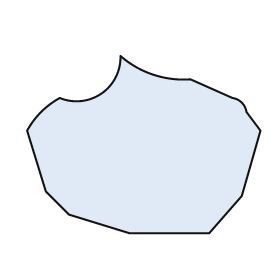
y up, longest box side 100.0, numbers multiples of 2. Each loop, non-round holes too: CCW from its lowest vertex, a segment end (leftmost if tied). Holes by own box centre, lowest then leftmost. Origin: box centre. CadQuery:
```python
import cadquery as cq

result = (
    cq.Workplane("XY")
    .moveTo(-6.0, -38.0)
    .lineTo(28.0, -38.0)
    .lineTo(42.0, -22.0)
    .lineTo(50.0, 6.0)
    .lineTo(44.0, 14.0)
    .threePointArc((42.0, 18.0), (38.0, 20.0))
    .lineTo(20.0, 28.0)
    .threePointArc((4.0, 30.0), (-10.0, 38.0))
    .threePointArc((-18.0, 22.0), (-36.0, 20.0))
    .threePointArc((-44.0, 14.0), (-50.0, 6.0))
    .lineTo(-42.0, -20.0)
    .lineTo(-32.0, -30.0)
    .close()
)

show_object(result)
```